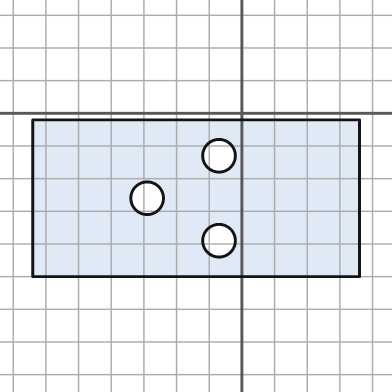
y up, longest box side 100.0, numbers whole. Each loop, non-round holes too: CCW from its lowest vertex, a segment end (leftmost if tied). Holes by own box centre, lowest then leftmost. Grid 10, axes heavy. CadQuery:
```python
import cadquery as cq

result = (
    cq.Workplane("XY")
    .moveTo(-64.0, -50.0)
    .lineTo(36.0, -50.0)
    .lineTo(36.0, -2.0)
    .lineTo(-64.0, -2.0)
    .close()
    .moveTo(-7.0, -39.0)
    .circle(5.0)
    .moveTo(-29.0, -26.0)
    .circle(5.0)
    .moveTo(-7.0, -13.0)
    .circle(5.0)
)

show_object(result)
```